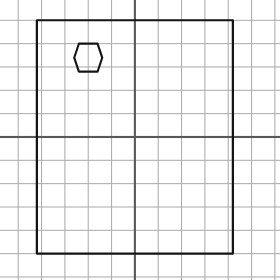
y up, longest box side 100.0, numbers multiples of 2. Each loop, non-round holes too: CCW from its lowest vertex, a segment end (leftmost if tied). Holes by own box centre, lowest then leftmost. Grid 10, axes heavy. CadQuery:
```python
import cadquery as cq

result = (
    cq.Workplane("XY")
    .moveTo(-42.0, -50.0)
    .lineTo(42.0, -50.0)
    .lineTo(42.0, 50.0)
    .lineTo(-42.0, 50.0)
    .close()
    .moveTo(-24.0, 28.0)
    .lineTo(-16.0, 28.0)
    .lineTo(-14.0, 34.0)
    .lineTo(-16.0, 40.0)
    .lineTo(-24.0, 40.0)
    .lineTo(-26.0, 34.0)
    .close()
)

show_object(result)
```